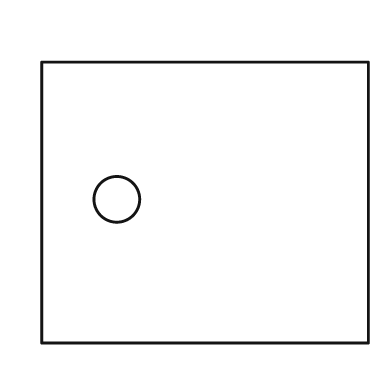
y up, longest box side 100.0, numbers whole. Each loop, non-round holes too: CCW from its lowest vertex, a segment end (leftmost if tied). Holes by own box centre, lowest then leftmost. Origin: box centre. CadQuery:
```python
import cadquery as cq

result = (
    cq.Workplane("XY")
    .moveTo(-50.0, -43.0)
    .lineTo(50.0, -43.0)
    .lineTo(50.0, 43.0)
    .lineTo(-50.0, 43.0)
    .close()
    .moveTo(-27.0, 1.0)
    .circle(7.0)
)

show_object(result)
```